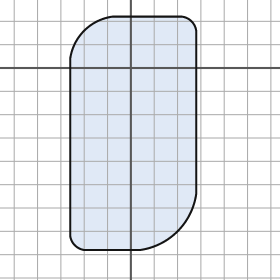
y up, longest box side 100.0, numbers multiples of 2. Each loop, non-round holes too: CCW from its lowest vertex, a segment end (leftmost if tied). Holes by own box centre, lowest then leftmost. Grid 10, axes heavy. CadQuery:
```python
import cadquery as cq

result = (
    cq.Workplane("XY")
    .moveTo(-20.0, -78.0)
    .lineTo(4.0, -78.0)
    .threePointArc((20.0, -70.0), (28.0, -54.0))
    .lineTo(28.0, 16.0)
    .threePointArc((26.0, 20.0), (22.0, 22.0))
    .lineTo(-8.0, 22.0)
    .threePointArc((-20.0, 16.0), (-26.0, 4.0))
    .lineTo(-26.0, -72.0)
    .threePointArc((-24.0, -76.0), (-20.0, -78.0))
    .close()
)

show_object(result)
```